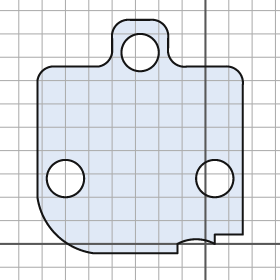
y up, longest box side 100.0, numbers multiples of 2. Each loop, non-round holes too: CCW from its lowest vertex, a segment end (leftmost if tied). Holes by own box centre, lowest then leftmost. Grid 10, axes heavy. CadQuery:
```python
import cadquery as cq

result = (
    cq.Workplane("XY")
    .moveTo(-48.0, -4.0)
    .lineTo(-12.0, -4.0)
    .lineTo(-12.0, 0.0)
    .threePointArc((-4.0, 2.0), (4.0, 0.0))
    .lineTo(4.0, 4.0)
    .lineTo(16.0, 4.0)
    .lineTo(16.0, 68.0)
    .threePointArc((14.0, 74.0), (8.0, 76.0))
    .lineTo(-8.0, 76.0)
    .threePointArc((-14.0, 78.0), (-16.0, 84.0))
    .lineTo(-16.0, 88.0)
    .threePointArc((-18.0, 94.0), (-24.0, 96.0))
    .lineTo(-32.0, 96.0)
    .threePointArc((-38.0, 94.0), (-40.0, 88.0))
    .lineTo(-40.0, 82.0)
    .threePointArc((-42.0, 78.0), (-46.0, 76.0))
    .lineTo(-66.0, 76.0)
    .threePointArc((-70.0, 74.0), (-72.0, 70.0))
    .lineTo(-72.0, 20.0)
    .threePointArc((-64.0, 4.0), (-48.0, -4.0))
    .close()
    .moveTo(-60.0, 28.0)
    .circle(8.0)
    .moveTo(4.0, 28.0)
    .circle(8.0)
    .moveTo(-28.0, 82.0)
    .circle(8.0)
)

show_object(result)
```